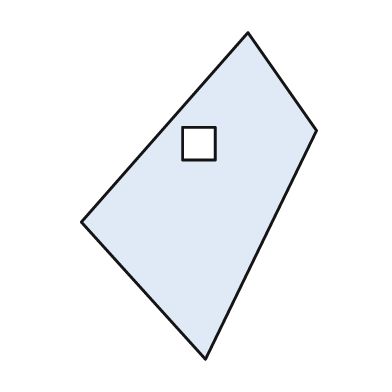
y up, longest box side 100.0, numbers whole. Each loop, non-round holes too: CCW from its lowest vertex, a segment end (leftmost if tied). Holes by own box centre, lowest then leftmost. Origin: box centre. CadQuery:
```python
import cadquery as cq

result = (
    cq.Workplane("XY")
    .moveTo(2.0, -50.0)
    .lineTo(36.0, 20.0)
    .lineTo(15.0, 50.0)
    .lineTo(-36.0, -8.0)
    .close()
    .moveTo(-5.0, 11.0)
    .lineTo(5.0, 11.0)
    .lineTo(5.0, 21.0)
    .lineTo(-5.0, 21.0)
    .close()
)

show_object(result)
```